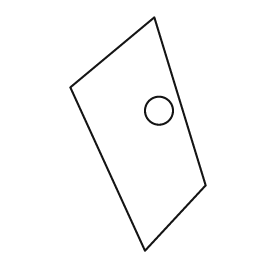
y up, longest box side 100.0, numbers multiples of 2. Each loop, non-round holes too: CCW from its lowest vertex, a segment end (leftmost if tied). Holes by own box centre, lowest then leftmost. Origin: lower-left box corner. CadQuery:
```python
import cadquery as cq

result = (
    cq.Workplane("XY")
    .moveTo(32.0, 0.0)
    .lineTo(58.0, 28.0)
    .lineTo(36.0, 100.0)
    .lineTo(0.0, 70.0)
    .close()
    .moveTo(38.0, 60.0)
    .circle(6.0)
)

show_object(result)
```